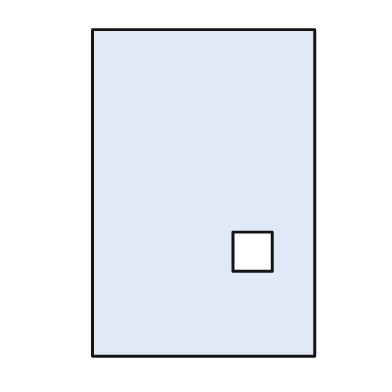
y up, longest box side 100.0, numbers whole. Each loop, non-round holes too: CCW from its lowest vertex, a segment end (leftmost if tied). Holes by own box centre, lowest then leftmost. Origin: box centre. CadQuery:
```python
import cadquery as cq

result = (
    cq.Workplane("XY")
    .moveTo(-34.0, -50.0)
    .lineTo(34.0, -50.0)
    .lineTo(34.0, 50.0)
    .lineTo(-34.0, 50.0)
    .close()
    .moveTo(9.0, -24.0)
    .lineTo(21.0, -24.0)
    .lineTo(21.0, -12.0)
    .lineTo(9.0, -12.0)
    .close()
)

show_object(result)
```